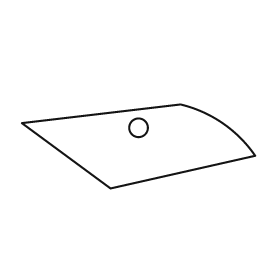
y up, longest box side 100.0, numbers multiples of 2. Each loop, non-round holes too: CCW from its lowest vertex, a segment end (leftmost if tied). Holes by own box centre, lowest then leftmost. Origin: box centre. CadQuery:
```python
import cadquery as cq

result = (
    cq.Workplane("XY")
    .moveTo(-12.0, -18.0)
    .lineTo(50.0, -4.0)
    .threePointArc((36.0, 10.0), (18.0, 18.0))
    .lineTo(-50.0, 10.0)
    .close()
    .moveTo(0.0, 8.0)
    .circle(4.0)
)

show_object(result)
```